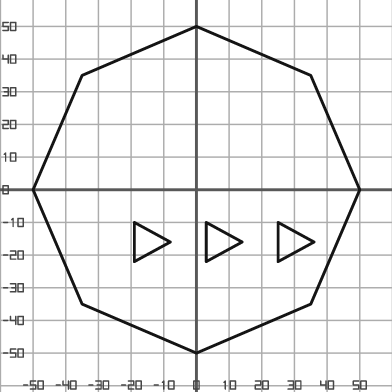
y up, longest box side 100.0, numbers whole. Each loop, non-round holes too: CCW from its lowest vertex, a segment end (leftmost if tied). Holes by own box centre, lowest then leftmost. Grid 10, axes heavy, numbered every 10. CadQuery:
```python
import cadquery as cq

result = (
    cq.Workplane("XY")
    .moveTo(0.0, -50.0)
    .lineTo(35.0, -35.0)
    .lineTo(50.0, 0.0)
    .lineTo(35.0, 35.0)
    .lineTo(0.0, 50.0)
    .lineTo(-35.0, 35.0)
    .lineTo(-50.0, 0.0)
    .lineTo(-35.0, -35.0)
    .close()
    .moveTo(-19.0, -22.0)
    .lineTo(-8.0, -16.0)
    .lineTo(-19.0, -10.0)
    .close()
    .moveTo(3.0, -22.0)
    .lineTo(14.0, -16.0)
    .lineTo(3.0, -10.0)
    .close()
    .moveTo(25.0, -22.0)
    .lineTo(36.0, -16.0)
    .lineTo(25.0, -10.0)
    .close()
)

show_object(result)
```